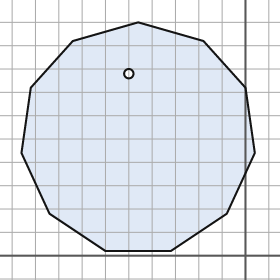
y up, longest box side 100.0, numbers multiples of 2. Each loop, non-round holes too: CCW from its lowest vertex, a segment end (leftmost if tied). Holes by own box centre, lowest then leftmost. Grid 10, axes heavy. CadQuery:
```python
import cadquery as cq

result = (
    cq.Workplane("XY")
    .moveTo(-60.0, 2.0)
    .lineTo(-32.0, 2.0)
    .lineTo(-8.0, 18.0)
    .lineTo(4.0, 44.0)
    .lineTo(0.0, 72.0)
    .lineTo(-18.0, 92.0)
    .lineTo(-46.0, 100.0)
    .lineTo(-74.0, 92.0)
    .lineTo(-92.0, 72.0)
    .lineTo(-96.0, 44.0)
    .lineTo(-84.0, 18.0)
    .close()
    .moveTo(-50.0, 78.0)
    .circle(2.0)
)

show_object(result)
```